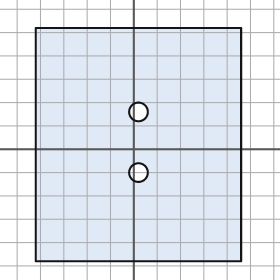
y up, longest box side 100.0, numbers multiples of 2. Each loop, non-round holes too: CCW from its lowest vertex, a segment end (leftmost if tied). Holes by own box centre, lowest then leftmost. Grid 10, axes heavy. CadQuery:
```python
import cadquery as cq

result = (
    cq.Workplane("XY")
    .moveTo(-42.0, -48.0)
    .lineTo(46.0, -48.0)
    .lineTo(46.0, 52.0)
    .lineTo(-42.0, 52.0)
    .close()
    .moveTo(2.0, -10.0)
    .circle(4.0)
    .moveTo(2.0, 16.0)
    .circle(4.0)
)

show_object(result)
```